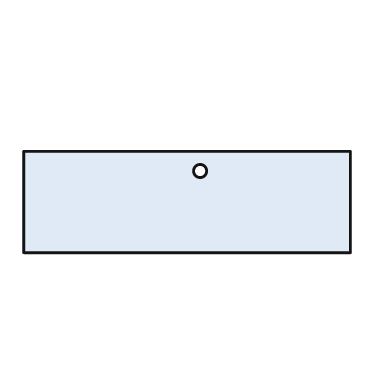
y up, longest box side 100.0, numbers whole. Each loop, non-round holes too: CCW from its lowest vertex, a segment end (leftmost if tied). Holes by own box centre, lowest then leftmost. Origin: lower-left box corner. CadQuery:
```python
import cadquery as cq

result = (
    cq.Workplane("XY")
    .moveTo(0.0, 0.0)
    .lineTo(100.0, 0.0)
    .lineTo(100.0, 31.0)
    .lineTo(0.0, 31.0)
    .close()
    .moveTo(54.0, 25.0)
    .circle(2.0)
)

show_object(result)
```